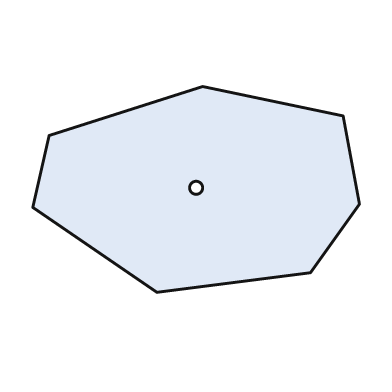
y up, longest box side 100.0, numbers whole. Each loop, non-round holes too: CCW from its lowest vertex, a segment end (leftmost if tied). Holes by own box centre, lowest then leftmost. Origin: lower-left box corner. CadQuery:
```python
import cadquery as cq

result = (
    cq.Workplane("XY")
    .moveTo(38.0, 0.0)
    .lineTo(85.0, 6.0)
    .lineTo(100.0, 27.0)
    .lineTo(95.0, 54.0)
    .lineTo(52.0, 63.0)
    .lineTo(5.0, 48.0)
    .lineTo(0.0, 26.0)
    .close()
    .moveTo(50.0, 32.0)
    .circle(2.0)
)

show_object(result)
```